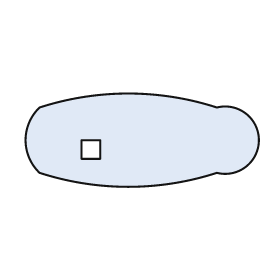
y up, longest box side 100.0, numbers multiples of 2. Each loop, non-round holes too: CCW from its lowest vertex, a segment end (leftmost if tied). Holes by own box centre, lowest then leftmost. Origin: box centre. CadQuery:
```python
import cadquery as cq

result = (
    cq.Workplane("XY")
    .moveTo(-44.0, -14.0)
    .threePointArc((-6.0, -20.0), (32.0, -14.0))
    .threePointArc((50.0, 0.0), (32.0, 14.0))
    .threePointArc((-6.0, 20.0), (-44.0, 14.0))
    .threePointArc((-50.0, 0.0), (-44.0, -14.0))
    .close()
    .moveTo(-26.0, -8.0)
    .lineTo(-18.0, -8.0)
    .lineTo(-18.0, 0.0)
    .lineTo(-26.0, 0.0)
    .close()
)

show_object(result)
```